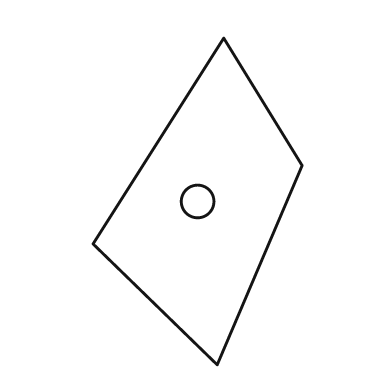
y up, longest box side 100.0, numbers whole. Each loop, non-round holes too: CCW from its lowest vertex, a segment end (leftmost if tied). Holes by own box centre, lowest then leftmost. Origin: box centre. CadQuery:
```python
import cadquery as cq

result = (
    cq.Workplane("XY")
    .moveTo(6.0, -50.0)
    .lineTo(32.0, 11.0)
    .lineTo(8.0, 50.0)
    .lineTo(-32.0, -13.0)
    .close()
    .moveTo(0.0, 0.0)
    .circle(5.0)
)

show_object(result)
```